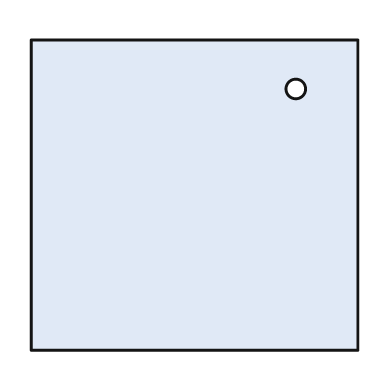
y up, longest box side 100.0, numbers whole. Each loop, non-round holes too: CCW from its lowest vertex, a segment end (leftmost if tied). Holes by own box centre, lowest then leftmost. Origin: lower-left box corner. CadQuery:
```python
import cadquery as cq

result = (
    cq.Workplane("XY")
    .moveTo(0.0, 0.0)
    .lineTo(100.0, 0.0)
    .lineTo(100.0, 95.0)
    .lineTo(0.0, 95.0)
    .close()
    .moveTo(81.0, 80.0)
    .circle(3.0)
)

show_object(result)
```